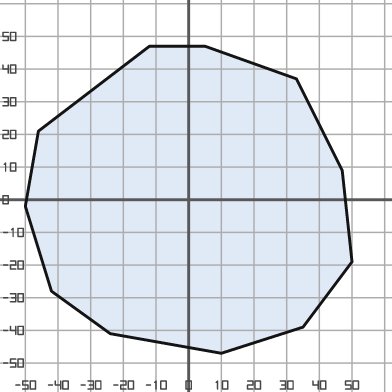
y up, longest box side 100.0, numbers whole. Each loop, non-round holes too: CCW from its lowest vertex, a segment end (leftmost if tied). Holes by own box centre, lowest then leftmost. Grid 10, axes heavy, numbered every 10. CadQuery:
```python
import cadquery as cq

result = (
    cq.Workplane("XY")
    .moveTo(10.0, -47.0)
    .lineTo(35.0, -39.0)
    .lineTo(50.0, -19.0)
    .lineTo(47.0, 9.0)
    .lineTo(33.0, 37.0)
    .lineTo(5.0, 47.0)
    .lineTo(-12.0, 47.0)
    .lineTo(-46.0, 21.0)
    .lineTo(-50.0, -2.0)
    .lineTo(-42.0, -28.0)
    .lineTo(-24.0, -41.0)
    .close()
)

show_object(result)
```